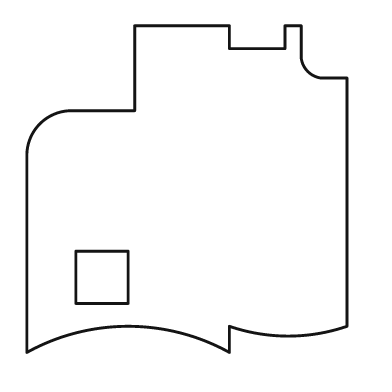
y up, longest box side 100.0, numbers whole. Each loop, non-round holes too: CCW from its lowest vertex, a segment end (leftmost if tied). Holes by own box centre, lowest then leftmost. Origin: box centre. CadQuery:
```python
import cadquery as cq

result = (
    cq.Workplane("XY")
    .moveTo(-49.0, -50.0)
    .threePointArc((-18.0, -42.0), (13.0, -50.0))
    .lineTo(13.0, -42.0)
    .threePointArc((31.0, -45.0), (49.0, -42.0))
    .lineTo(49.0, 34.0)
    .lineTo(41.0, 34.0)
    .threePointArc((37.0, 36.0), (35.0, 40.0))
    .lineTo(35.0, 50.0)
    .lineTo(30.0, 50.0)
    .lineTo(30.0, 43.0)
    .lineTo(13.0, 43.0)
    .lineTo(13.0, 50.0)
    .lineTo(-16.0, 50.0)
    .lineTo(-16.0, 24.0)
    .lineTo(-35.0, 24.0)
    .threePointArc((-45.0, 20.0), (-49.0, 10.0))
    .close()
    .moveTo(-34.0, -35.0)
    .lineTo(-18.0, -35.0)
    .lineTo(-18.0, -19.0)
    .lineTo(-34.0, -19.0)
    .close()
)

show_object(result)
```